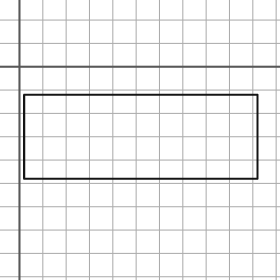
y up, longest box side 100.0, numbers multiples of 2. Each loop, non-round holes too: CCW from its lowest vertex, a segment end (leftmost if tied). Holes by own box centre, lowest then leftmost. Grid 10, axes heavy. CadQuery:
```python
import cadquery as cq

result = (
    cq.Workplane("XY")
    .moveTo(2.0, -48.0)
    .lineTo(102.0, -48.0)
    .lineTo(102.0, -12.0)
    .lineTo(2.0, -12.0)
    .close()
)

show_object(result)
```